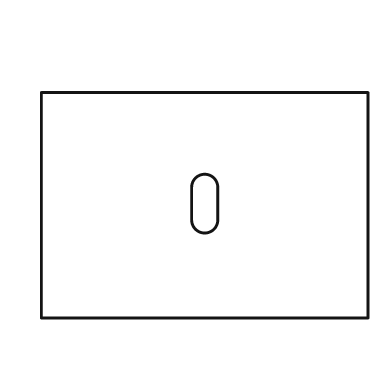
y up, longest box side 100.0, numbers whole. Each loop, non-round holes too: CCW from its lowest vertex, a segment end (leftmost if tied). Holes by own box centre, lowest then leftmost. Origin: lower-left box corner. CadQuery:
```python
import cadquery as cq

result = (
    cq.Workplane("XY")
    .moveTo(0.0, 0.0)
    .lineTo(100.0, 0.0)
    .lineTo(100.0, 69.0)
    .lineTo(0.0, 69.0)
    .close()
    .moveTo(46.0, 30.0)
    .threePointArc((50.0, 26.0), (54.0, 30.0))
    .lineTo(54.0, 40.0)
    .threePointArc((50.0, 44.0), (46.0, 40.0))
    .close()
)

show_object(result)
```